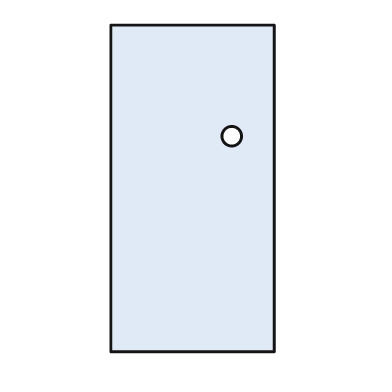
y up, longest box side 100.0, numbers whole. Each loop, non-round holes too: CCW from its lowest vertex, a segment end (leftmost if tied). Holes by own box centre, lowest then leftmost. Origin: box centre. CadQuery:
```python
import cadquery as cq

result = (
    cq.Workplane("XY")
    .moveTo(-25.0, -50.0)
    .lineTo(25.0, -50.0)
    .lineTo(25.0, 50.0)
    .lineTo(-25.0, 50.0)
    .close()
    .moveTo(12.0, 16.0)
    .circle(3.0)
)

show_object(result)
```